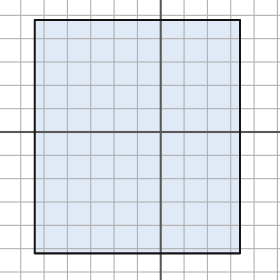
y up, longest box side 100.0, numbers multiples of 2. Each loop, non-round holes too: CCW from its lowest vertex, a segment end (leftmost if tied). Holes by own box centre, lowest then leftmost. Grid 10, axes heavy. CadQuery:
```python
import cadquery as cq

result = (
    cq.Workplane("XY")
    .moveTo(-54.0, -52.0)
    .lineTo(34.0, -52.0)
    .lineTo(34.0, 48.0)
    .lineTo(-54.0, 48.0)
    .close()
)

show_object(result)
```